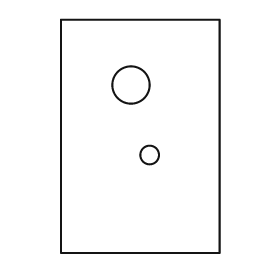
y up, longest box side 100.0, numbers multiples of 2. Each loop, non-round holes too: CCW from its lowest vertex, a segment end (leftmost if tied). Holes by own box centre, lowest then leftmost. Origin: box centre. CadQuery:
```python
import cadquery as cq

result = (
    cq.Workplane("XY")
    .moveTo(-34.0, -50.0)
    .lineTo(34.0, -50.0)
    .lineTo(34.0, 50.0)
    .lineTo(-34.0, 50.0)
    .close()
    .moveTo(4.0, -8.0)
    .circle(4.0)
    .moveTo(-4.0, 22.0)
    .circle(8.0)
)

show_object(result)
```